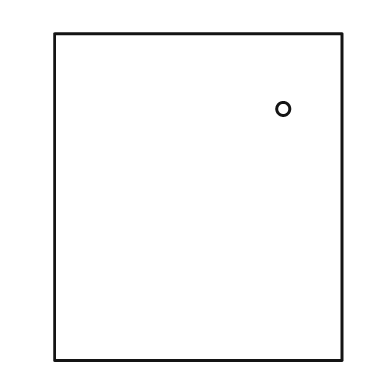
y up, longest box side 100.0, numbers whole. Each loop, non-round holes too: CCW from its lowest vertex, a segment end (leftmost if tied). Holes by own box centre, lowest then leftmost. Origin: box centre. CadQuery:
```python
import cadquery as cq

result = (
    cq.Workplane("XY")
    .moveTo(-44.0, -50.0)
    .lineTo(44.0, -50.0)
    .lineTo(44.0, 50.0)
    .lineTo(-44.0, 50.0)
    .close()
    .moveTo(26.0, 27.0)
    .circle(2.0)
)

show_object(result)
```